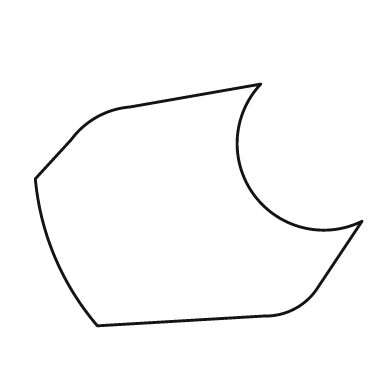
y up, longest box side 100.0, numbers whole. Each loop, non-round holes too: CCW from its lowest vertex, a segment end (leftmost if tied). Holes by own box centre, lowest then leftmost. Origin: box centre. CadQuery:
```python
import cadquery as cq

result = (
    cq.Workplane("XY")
    .moveTo(-31.0, -37.0)
    .lineTo(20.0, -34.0)
    .threePointArc((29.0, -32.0), (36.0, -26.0))
    .lineTo(50.0, -5.0)
    .threePointArc((17.0, 3.0), (19.0, 37.0))
    .lineTo(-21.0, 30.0)
    .threePointArc((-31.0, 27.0), (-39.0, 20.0))
    .lineTo(-50.0, 8.0)
    .threePointArc((-44.0, -16.0), (-31.0, -37.0))
    .close()
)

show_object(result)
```